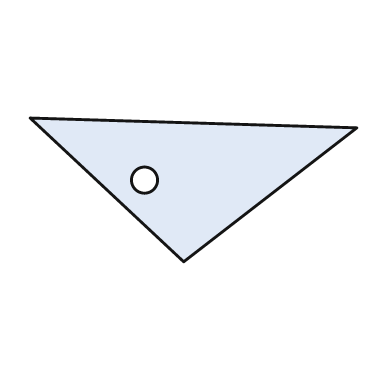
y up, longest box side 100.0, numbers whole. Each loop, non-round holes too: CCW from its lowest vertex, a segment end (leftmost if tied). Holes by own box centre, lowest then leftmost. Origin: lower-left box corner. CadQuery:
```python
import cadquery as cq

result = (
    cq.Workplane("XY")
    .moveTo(47.0, 0.0)
    .lineTo(100.0, 41.0)
    .lineTo(0.0, 44.0)
    .close()
    .moveTo(35.0, 25.0)
    .circle(4.0)
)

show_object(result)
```